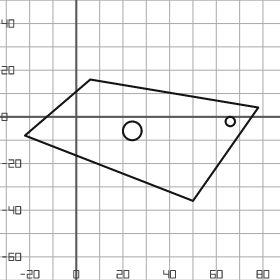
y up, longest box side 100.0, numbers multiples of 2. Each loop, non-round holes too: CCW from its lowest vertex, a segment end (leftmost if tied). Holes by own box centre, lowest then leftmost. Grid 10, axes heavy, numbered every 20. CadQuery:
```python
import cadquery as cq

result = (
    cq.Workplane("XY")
    .moveTo(50.0, -36.0)
    .lineTo(78.0, 4.0)
    .lineTo(6.0, 16.0)
    .lineTo(-22.0, -8.0)
    .close()
    .moveTo(24.0, -6.0)
    .circle(4.0)
    .moveTo(66.0, -2.0)
    .circle(2.0)
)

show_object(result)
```